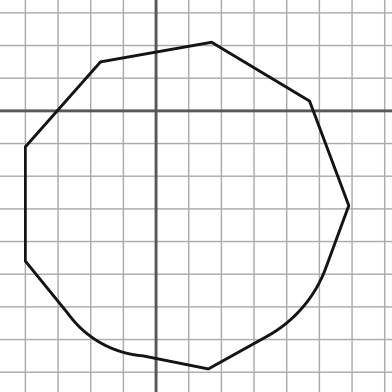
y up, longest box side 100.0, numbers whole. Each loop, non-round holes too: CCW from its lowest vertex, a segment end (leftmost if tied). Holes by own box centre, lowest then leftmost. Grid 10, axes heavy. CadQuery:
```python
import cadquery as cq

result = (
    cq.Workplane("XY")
    .moveTo(16.0, -79.0)
    .lineTo(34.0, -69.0)
    .threePointArc((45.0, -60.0), (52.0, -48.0))
    .lineTo(59.0, -29.0)
    .lineTo(47.0, 3.0)
    .lineTo(17.0, 21.0)
    .lineTo(-17.0, 15.0)
    .lineTo(-40.0, -11.0)
    .lineTo(-40.0, -46.0)
    .lineTo(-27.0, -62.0)
    .threePointArc((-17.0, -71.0), (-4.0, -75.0))
    .close()
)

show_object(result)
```